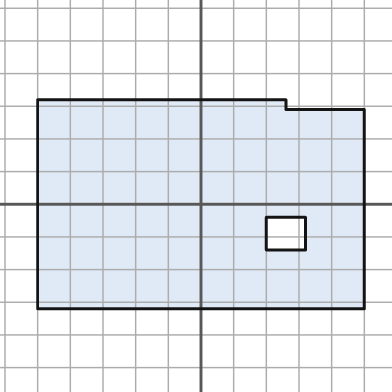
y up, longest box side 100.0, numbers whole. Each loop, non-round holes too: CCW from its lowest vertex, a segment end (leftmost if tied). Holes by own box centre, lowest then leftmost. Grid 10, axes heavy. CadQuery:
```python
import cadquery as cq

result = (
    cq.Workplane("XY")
    .moveTo(-50.0, -32.0)
    .lineTo(50.0, -32.0)
    .lineTo(50.0, 29.0)
    .lineTo(26.0, 29.0)
    .lineTo(26.0, 32.0)
    .lineTo(-50.0, 32.0)
    .close()
    .moveTo(20.0, -14.0)
    .lineTo(32.0, -14.0)
    .lineTo(32.0, -4.0)
    .lineTo(20.0, -4.0)
    .close()
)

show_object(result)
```